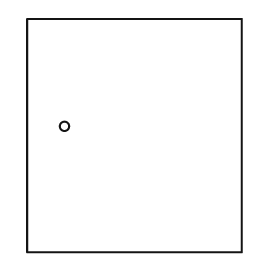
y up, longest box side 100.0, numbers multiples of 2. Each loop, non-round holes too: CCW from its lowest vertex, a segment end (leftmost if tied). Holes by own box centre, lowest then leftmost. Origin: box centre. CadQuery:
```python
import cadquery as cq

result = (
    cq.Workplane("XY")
    .moveTo(-46.0, -50.0)
    .lineTo(46.0, -50.0)
    .lineTo(46.0, 50.0)
    .lineTo(-46.0, 50.0)
    .close()
    .moveTo(-30.0, 4.0)
    .circle(2.0)
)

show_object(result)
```